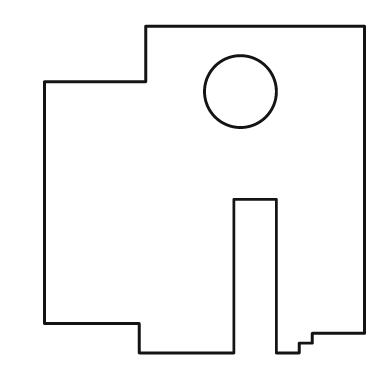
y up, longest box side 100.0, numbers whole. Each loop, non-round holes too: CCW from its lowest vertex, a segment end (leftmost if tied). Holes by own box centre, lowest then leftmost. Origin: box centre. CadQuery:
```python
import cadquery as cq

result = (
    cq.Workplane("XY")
    .moveTo(-20.0, -50.0)
    .lineTo(9.0, -50.0)
    .lineTo(9.0, -3.0)
    .lineTo(22.0, -3.0)
    .lineTo(22.0, -50.0)
    .lineTo(29.0, -50.0)
    .lineTo(29.0, -47.0)
    .lineTo(33.0, -47.0)
    .lineTo(33.0, -44.0)
    .lineTo(49.0, -44.0)
    .lineTo(49.0, 50.0)
    .lineTo(-18.0, 50.0)
    .lineTo(-18.0, 33.0)
    .lineTo(-49.0, 33.0)
    .lineTo(-49.0, -41.0)
    .lineTo(-20.0, -41.0)
    .close()
    .moveTo(11.0, 30.0)
    .circle(11.0)
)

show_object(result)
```